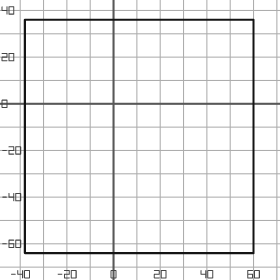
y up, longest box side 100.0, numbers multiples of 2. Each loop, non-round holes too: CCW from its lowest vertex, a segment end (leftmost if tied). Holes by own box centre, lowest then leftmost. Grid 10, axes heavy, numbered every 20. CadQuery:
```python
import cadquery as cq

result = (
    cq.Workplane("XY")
    .moveTo(-38.0, -64.0)
    .lineTo(60.0, -64.0)
    .lineTo(60.0, 36.0)
    .lineTo(-38.0, 36.0)
    .close()
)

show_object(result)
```